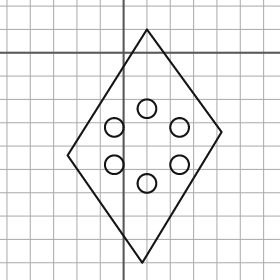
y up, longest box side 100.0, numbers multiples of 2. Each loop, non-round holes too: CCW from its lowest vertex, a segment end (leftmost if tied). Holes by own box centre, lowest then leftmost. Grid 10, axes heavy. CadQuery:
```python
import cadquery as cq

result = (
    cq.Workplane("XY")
    .moveTo(8.0, -90.0)
    .lineTo(42.0, -34.0)
    .lineTo(10.0, 10.0)
    .lineTo(-24.0, -44.0)
    .close()
    .moveTo(10.0, -56.0)
    .circle(4.0)
    .moveTo(-4.0, -48.0)
    .circle(4.0)
    .moveTo(24.0, -48.0)
    .circle(4.0)
    .moveTo(-4.0, -32.0)
    .circle(4.0)
    .moveTo(24.0, -32.0)
    .circle(4.0)
    .moveTo(10.0, -24.0)
    .circle(4.0)
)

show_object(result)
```